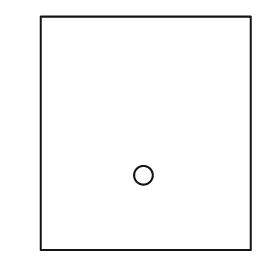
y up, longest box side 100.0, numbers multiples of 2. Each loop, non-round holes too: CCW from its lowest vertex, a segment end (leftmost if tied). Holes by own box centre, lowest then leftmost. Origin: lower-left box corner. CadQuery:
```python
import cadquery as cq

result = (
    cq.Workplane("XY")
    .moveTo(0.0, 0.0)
    .lineTo(90.0, 0.0)
    .lineTo(90.0, 100.0)
    .lineTo(0.0, 100.0)
    .close()
    .moveTo(44.0, 32.0)
    .circle(4.0)
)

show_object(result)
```